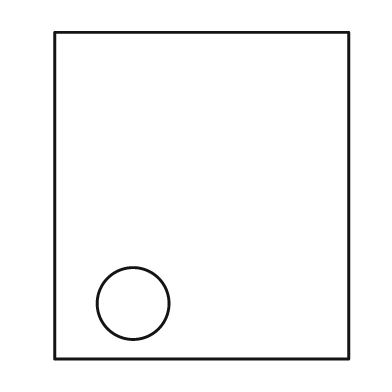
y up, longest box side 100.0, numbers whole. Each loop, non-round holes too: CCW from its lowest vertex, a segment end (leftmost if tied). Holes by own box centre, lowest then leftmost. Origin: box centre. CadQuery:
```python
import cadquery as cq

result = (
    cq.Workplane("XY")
    .moveTo(-45.0, -50.0)
    .lineTo(45.0, -50.0)
    .lineTo(45.0, 50.0)
    .lineTo(-45.0, 50.0)
    .close()
    .moveTo(-21.0, -33.0)
    .circle(11.0)
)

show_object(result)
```